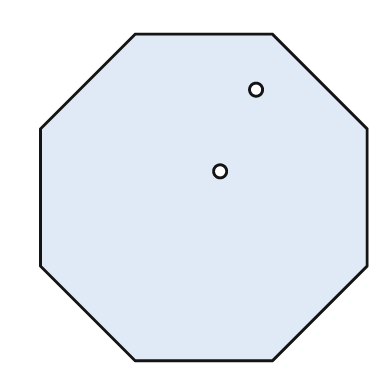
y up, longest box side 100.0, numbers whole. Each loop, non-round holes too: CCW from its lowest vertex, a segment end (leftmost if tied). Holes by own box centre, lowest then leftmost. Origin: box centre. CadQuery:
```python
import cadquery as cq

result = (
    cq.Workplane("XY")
    .moveTo(-21.0, -50.0)
    .lineTo(21.0, -50.0)
    .lineTo(50.0, -21.0)
    .lineTo(50.0, 21.0)
    .lineTo(21.0, 50.0)
    .lineTo(-21.0, 50.0)
    .lineTo(-50.0, 21.0)
    .lineTo(-50.0, -21.0)
    .close()
    .moveTo(5.0, 8.0)
    .circle(2.0)
    .moveTo(16.0, 33.0)
    .circle(2.0)
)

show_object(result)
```